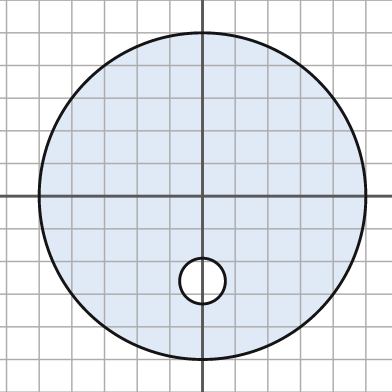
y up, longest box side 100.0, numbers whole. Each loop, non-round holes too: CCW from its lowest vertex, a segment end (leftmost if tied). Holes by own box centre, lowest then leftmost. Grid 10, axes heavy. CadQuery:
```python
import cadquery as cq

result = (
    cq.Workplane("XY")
    .moveTo(0.0, 0.0)
    .circle(50.0)
    .moveTo(0.0, -26.0)
    .circle(7.0)
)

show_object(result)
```